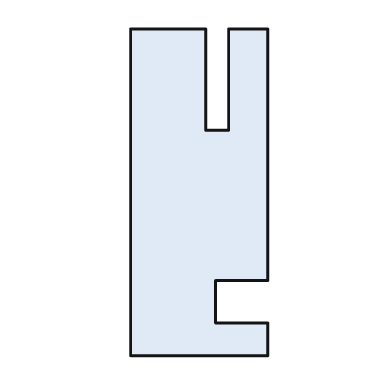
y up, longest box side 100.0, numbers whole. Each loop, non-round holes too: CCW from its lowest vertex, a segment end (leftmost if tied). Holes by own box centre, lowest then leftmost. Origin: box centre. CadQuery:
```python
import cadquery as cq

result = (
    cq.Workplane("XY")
    .moveTo(-21.0, -50.0)
    .lineTo(21.0, -50.0)
    .lineTo(21.0, -40.0)
    .lineTo(5.0, -40.0)
    .lineTo(5.0, -27.0)
    .lineTo(21.0, -27.0)
    .lineTo(21.0, 50.0)
    .lineTo(9.0, 50.0)
    .lineTo(9.0, 19.0)
    .lineTo(2.0, 19.0)
    .lineTo(2.0, 50.0)
    .lineTo(-21.0, 50.0)
    .close()
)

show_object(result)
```